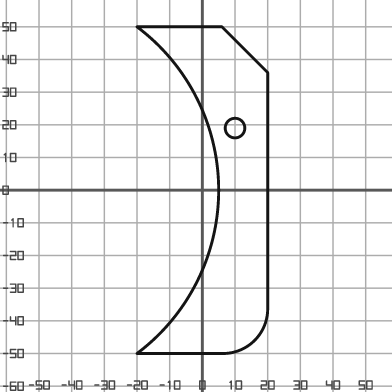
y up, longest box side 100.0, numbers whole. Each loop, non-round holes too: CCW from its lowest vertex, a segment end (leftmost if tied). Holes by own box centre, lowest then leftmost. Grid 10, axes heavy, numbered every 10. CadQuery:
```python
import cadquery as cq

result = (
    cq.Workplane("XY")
    .moveTo(-20.0, -50.0)
    .lineTo(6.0, -50.0)
    .threePointArc((16.0, -46.0), (20.0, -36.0))
    .lineTo(20.0, 36.0)
    .lineTo(6.0, 50.0)
    .lineTo(-20.0, 50.0)
    .threePointArc((5.0, 0.0), (-20.0, -50.0))
    .close()
    .moveTo(10.0, 19.0)
    .circle(3.0)
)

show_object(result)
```